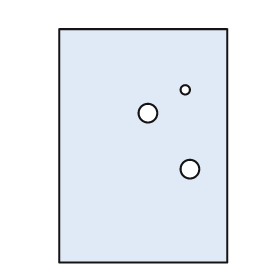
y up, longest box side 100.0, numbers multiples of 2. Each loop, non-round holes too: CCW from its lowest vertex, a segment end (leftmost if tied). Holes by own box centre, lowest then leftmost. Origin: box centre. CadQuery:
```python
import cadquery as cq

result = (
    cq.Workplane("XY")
    .moveTo(-36.0, -50.0)
    .lineTo(36.0, -50.0)
    .lineTo(36.0, 50.0)
    .lineTo(-36.0, 50.0)
    .close()
    .moveTo(20.0, -10.0)
    .circle(4.0)
    .moveTo(2.0, 14.0)
    .circle(4.0)
    .moveTo(18.0, 24.0)
    .circle(2.0)
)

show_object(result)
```